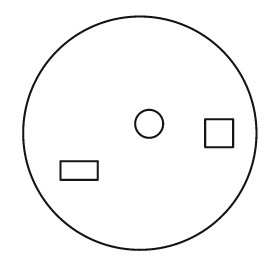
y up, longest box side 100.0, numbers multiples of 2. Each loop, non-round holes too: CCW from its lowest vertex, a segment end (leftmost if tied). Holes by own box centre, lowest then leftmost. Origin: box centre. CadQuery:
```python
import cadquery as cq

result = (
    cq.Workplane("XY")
    .moveTo(0.0, 0.0)
    .circle(50.0)
    .moveTo(-34.0, -20.0)
    .lineTo(-18.0, -20.0)
    .lineTo(-18.0, -12.0)
    .lineTo(-34.0, -12.0)
    .close()
    .moveTo(28.0, -6.0)
    .lineTo(40.0, -6.0)
    .lineTo(40.0, 6.0)
    .lineTo(28.0, 6.0)
    .close()
    .moveTo(4.0, 4.0)
    .circle(6.0)
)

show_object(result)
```